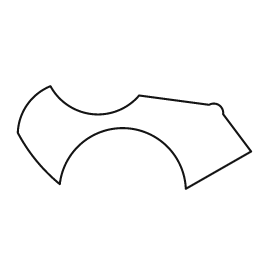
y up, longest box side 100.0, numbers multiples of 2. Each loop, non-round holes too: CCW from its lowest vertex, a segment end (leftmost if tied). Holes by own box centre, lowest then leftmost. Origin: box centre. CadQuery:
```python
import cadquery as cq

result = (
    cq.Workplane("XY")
    .moveTo(22.0, -22.0)
    .lineTo(50.0, -6.0)
    .lineTo(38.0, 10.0)
    .threePointArc((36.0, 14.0), (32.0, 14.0))
    .lineTo(2.0, 18.0)
    .threePointArc((-18.0, 10.0), (-36.0, 22.0))
    .threePointArc((-46.0, 14.0), (-50.0, 2.0))
    .threePointArc((-42.0, -10.0), (-32.0, -20.0))
    .threePointArc((-4.0, 4.0), (22.0, -22.0))
    .close()
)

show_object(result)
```